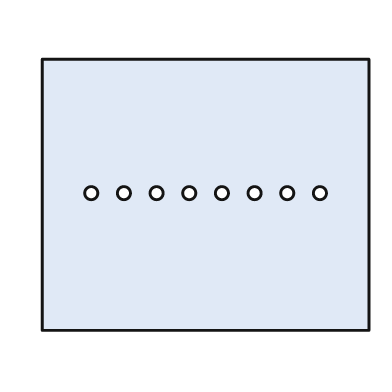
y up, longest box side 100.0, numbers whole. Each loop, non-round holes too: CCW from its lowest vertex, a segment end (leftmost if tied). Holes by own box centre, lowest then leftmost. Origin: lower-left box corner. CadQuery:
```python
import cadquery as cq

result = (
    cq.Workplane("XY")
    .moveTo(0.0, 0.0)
    .lineTo(100.0, 0.0)
    .lineTo(100.0, 83.0)
    .lineTo(0.0, 83.0)
    .close()
    .moveTo(15.0, 42.0)
    .circle(2.0)
    .moveTo(25.0, 42.0)
    .circle(2.0)
    .moveTo(35.0, 42.0)
    .circle(2.0)
    .moveTo(45.0, 42.0)
    .circle(2.0)
    .moveTo(55.0, 42.0)
    .circle(2.0)
    .moveTo(65.0, 42.0)
    .circle(2.0)
    .moveTo(75.0, 42.0)
    .circle(2.0)
    .moveTo(85.0, 42.0)
    .circle(2.0)
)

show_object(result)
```